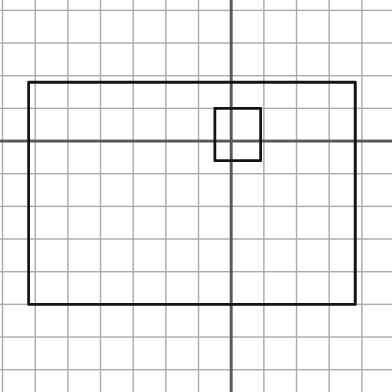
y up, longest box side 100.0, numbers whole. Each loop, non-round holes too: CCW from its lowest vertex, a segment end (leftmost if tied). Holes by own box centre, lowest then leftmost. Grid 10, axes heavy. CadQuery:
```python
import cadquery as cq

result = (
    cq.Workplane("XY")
    .moveTo(-62.0, -50.0)
    .lineTo(38.0, -50.0)
    .lineTo(38.0, 18.0)
    .lineTo(-62.0, 18.0)
    .close()
    .moveTo(-5.0, -6.0)
    .lineTo(9.0, -6.0)
    .lineTo(9.0, 10.0)
    .lineTo(-5.0, 10.0)
    .close()
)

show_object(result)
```